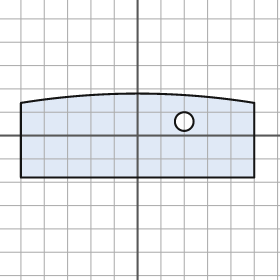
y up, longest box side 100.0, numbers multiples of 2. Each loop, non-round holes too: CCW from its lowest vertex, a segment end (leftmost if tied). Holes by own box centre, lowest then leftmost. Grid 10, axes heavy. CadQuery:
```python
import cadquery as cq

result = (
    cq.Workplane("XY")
    .moveTo(-50.0, -18.0)
    .lineTo(50.0, -18.0)
    .lineTo(50.0, 14.0)
    .threePointArc((0.0, 18.0), (-50.0, 14.0))
    .close()
    .moveTo(20.0, 6.0)
    .circle(4.0)
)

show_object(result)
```